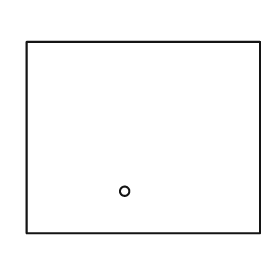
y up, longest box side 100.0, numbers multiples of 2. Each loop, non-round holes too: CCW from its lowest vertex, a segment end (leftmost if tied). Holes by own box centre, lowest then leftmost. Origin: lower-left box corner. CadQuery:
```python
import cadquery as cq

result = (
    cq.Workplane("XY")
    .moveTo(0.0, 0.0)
    .lineTo(100.0, 0.0)
    .lineTo(100.0, 82.0)
    .lineTo(0.0, 82.0)
    .close()
    .moveTo(42.0, 18.0)
    .circle(2.0)
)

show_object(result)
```